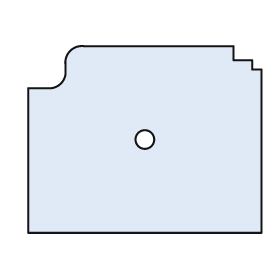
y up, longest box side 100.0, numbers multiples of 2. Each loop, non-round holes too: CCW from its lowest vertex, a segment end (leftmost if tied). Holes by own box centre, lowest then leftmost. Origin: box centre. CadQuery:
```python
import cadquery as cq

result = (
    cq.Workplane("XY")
    .moveTo(-50.0, -40.0)
    .lineTo(50.0, -40.0)
    .lineTo(50.0, 30.0)
    .lineTo(46.0, 30.0)
    .lineTo(46.0, 34.0)
    .lineTo(38.0, 34.0)
    .lineTo(38.0, 40.0)
    .lineTo(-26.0, 40.0)
    .threePointArc((-32.0, 38.0), (-34.0, 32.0))
    .lineTo(-34.0, 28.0)
    .threePointArc((-36.0, 24.0), (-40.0, 22.0))
    .lineTo(-50.0, 22.0)
    .close()
    .moveTo(0.0, 0.0)
    .circle(4.0)
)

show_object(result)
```